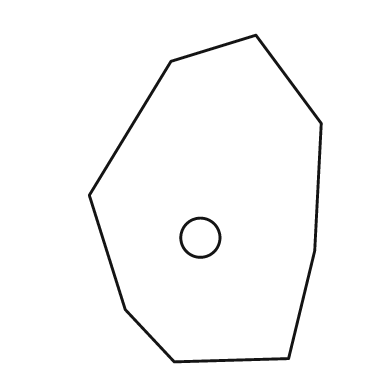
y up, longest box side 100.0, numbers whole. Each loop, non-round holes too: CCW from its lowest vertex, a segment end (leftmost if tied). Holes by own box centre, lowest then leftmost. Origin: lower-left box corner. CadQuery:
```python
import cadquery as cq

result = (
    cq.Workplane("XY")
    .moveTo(26.0, 0.0)
    .lineTo(61.0, 1.0)
    .lineTo(69.0, 34.0)
    .lineTo(71.0, 73.0)
    .lineTo(51.0, 100.0)
    .lineTo(25.0, 92.0)
    .lineTo(0.0, 51.0)
    .lineTo(11.0, 16.0)
    .close()
    .moveTo(34.0, 38.0)
    .circle(6.0)
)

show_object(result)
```